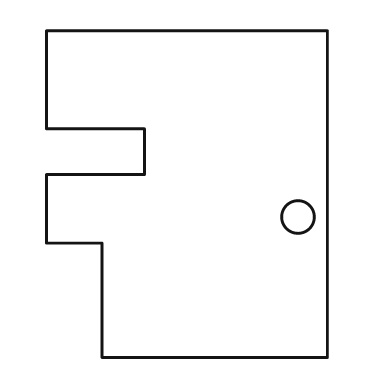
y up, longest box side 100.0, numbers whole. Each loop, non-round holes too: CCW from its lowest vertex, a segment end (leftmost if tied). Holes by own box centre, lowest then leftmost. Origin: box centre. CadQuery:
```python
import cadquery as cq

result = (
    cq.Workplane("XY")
    .moveTo(-26.0, -50.0)
    .lineTo(43.0, -50.0)
    .lineTo(43.0, 50.0)
    .lineTo(-43.0, 50.0)
    .lineTo(-43.0, 20.0)
    .lineTo(-13.0, 20.0)
    .lineTo(-13.0, 6.0)
    .lineTo(-43.0, 6.0)
    .lineTo(-43.0, -15.0)
    .lineTo(-26.0, -15.0)
    .close()
    .moveTo(34.0, -7.0)
    .circle(5.0)
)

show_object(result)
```